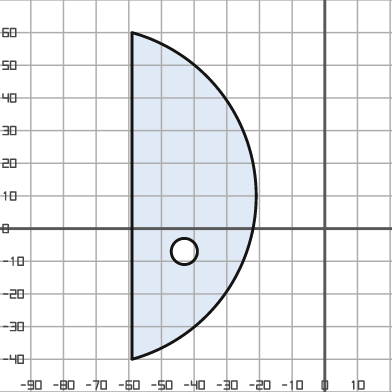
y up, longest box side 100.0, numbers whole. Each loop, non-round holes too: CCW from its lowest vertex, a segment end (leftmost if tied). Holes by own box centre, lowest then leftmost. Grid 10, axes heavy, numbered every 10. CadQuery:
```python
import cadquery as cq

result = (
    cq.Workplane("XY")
    .moveTo(-59.0, -40.0)
    .threePointArc((-21.0, 10.0), (-59.0, 60.0))
    .close()
    .moveTo(-43.0, -7.0)
    .circle(4.0)
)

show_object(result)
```